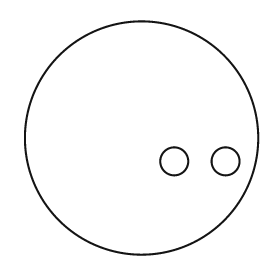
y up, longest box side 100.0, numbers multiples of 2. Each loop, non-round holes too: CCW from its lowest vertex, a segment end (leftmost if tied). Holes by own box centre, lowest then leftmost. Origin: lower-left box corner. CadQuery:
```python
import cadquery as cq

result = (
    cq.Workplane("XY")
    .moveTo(50.0, 50.0)
    .circle(50.0)
    .moveTo(64.0, 40.0)
    .circle(6.0)
    .moveTo(86.0, 40.0)
    .circle(6.0)
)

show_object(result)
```